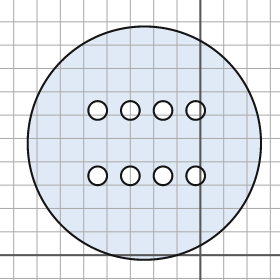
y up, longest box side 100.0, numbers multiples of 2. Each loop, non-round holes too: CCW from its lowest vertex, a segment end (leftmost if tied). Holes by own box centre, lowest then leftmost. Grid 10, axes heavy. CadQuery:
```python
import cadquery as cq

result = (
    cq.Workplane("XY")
    .moveTo(-24.0, 48.0)
    .circle(50.0)
    .moveTo(-44.0, 34.0)
    .circle(4.0)
    .moveTo(-30.0, 34.0)
    .circle(4.0)
    .moveTo(-16.0, 34.0)
    .circle(4.0)
    .moveTo(-2.0, 34.0)
    .circle(4.0)
    .moveTo(-44.0, 62.0)
    .circle(4.0)
    .moveTo(-30.0, 62.0)
    .circle(4.0)
    .moveTo(-16.0, 62.0)
    .circle(4.0)
    .moveTo(-2.0, 62.0)
    .circle(4.0)
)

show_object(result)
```